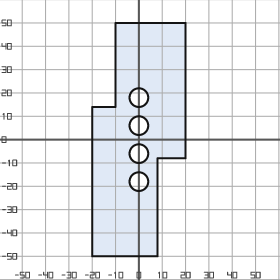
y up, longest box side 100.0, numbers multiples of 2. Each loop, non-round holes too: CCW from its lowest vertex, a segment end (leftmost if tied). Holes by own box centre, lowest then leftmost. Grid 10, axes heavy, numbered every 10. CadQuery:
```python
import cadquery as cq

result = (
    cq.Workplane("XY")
    .moveTo(-20.0, -50.0)
    .lineTo(8.0, -50.0)
    .lineTo(8.0, -8.0)
    .lineTo(20.0, -8.0)
    .lineTo(20.0, 50.0)
    .lineTo(-10.0, 50.0)
    .lineTo(-10.0, 14.0)
    .lineTo(-20.0, 14.0)
    .close()
    .moveTo(0.0, -18.0)
    .circle(4.0)
    .moveTo(0.0, -6.0)
    .circle(4.0)
    .moveTo(0.0, 6.0)
    .circle(4.0)
    .moveTo(0.0, 18.0)
    .circle(4.0)
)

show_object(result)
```